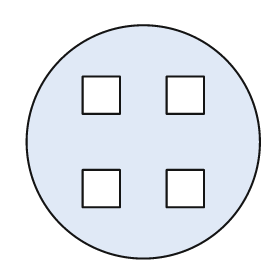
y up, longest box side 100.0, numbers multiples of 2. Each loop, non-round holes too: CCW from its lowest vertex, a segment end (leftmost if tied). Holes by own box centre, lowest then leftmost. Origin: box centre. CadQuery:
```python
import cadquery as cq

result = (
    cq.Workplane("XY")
    .moveTo(0.0, 0.0)
    .circle(50.0)
    .moveTo(-26.0, -28.0)
    .lineTo(-10.0, -28.0)
    .lineTo(-10.0, -12.0)
    .lineTo(-26.0, -12.0)
    .close()
    .moveTo(10.0, -28.0)
    .lineTo(26.0, -28.0)
    .lineTo(26.0, -12.0)
    .lineTo(10.0, -12.0)
    .close()
    .moveTo(-26.0, 12.0)
    .lineTo(-10.0, 12.0)
    .lineTo(-10.0, 28.0)
    .lineTo(-26.0, 28.0)
    .close()
    .moveTo(10.0, 12.0)
    .lineTo(26.0, 12.0)
    .lineTo(26.0, 28.0)
    .lineTo(10.0, 28.0)
    .close()
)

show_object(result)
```